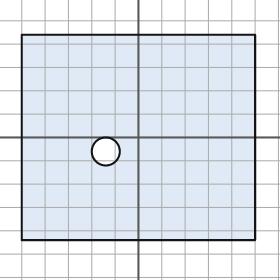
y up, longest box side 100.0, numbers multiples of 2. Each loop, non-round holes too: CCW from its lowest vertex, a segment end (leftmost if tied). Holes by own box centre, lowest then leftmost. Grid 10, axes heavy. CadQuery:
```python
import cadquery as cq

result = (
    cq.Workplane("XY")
    .moveTo(-50.0, -44.0)
    .lineTo(50.0, -44.0)
    .lineTo(50.0, 44.0)
    .lineTo(-50.0, 44.0)
    .close()
    .moveTo(-14.0, -6.0)
    .circle(6.0)
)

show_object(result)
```